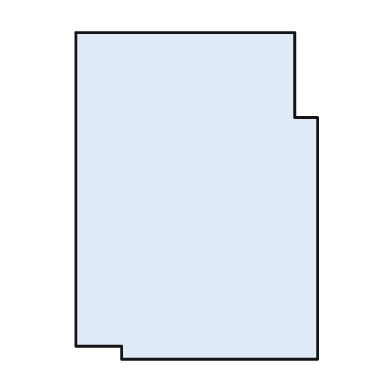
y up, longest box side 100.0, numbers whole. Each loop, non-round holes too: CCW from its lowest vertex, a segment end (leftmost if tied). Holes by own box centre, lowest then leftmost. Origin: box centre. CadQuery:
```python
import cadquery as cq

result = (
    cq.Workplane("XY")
    .moveTo(-23.0, -50.0)
    .lineTo(37.0, -50.0)
    .lineTo(37.0, 24.0)
    .lineTo(30.0, 24.0)
    .lineTo(30.0, 50.0)
    .lineTo(-37.0, 50.0)
    .lineTo(-37.0, -46.0)
    .lineTo(-23.0, -46.0)
    .close()
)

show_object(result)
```